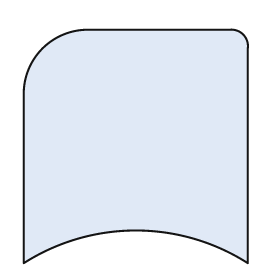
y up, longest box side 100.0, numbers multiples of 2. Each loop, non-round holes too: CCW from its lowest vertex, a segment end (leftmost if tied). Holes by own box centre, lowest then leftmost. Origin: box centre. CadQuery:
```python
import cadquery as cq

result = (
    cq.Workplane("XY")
    .moveTo(-48.0, -50.0)
    .threePointArc((0.0, -36.0), (48.0, -50.0))
    .lineTo(48.0, 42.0)
    .threePointArc((46.0, 48.0), (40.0, 50.0))
    .lineTo(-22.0, 50.0)
    .threePointArc((-40.0, 42.0), (-48.0, 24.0))
    .close()
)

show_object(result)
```